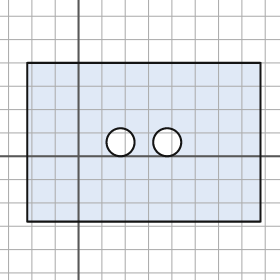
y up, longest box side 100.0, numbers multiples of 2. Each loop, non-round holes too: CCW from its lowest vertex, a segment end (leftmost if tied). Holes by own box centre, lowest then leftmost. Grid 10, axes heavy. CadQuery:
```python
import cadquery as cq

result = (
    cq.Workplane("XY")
    .moveTo(-22.0, -28.0)
    .lineTo(78.0, -28.0)
    .lineTo(78.0, 40.0)
    .lineTo(-22.0, 40.0)
    .close()
    .moveTo(18.0, 6.0)
    .circle(6.0)
    .moveTo(38.0, 6.0)
    .circle(6.0)
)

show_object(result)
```